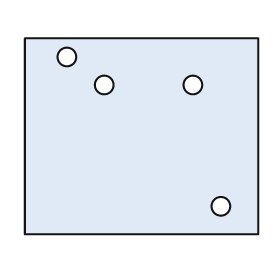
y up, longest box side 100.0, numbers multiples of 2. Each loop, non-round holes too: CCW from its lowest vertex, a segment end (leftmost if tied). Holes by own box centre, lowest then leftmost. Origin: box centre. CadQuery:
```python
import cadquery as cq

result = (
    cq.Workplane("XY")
    .moveTo(-50.0, -42.0)
    .lineTo(50.0, -42.0)
    .lineTo(50.0, 42.0)
    .lineTo(-50.0, 42.0)
    .close()
    .moveTo(34.0, -30.0)
    .circle(4.0)
    .moveTo(-16.0, 22.0)
    .circle(4.0)
    .moveTo(22.0, 22.0)
    .circle(4.0)
    .moveTo(-32.0, 34.0)
    .circle(4.0)
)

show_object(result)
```